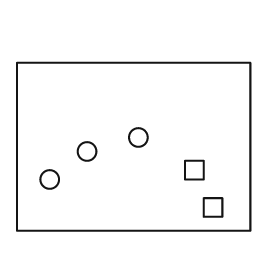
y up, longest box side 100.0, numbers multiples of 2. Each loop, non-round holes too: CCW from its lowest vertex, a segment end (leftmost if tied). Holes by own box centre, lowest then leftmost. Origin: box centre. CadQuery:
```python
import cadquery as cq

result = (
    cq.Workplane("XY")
    .moveTo(-50.0, -36.0)
    .lineTo(50.0, -36.0)
    .lineTo(50.0, 36.0)
    .lineTo(-50.0, 36.0)
    .close()
    .moveTo(30.0, -30.0)
    .lineTo(38.0, -30.0)
    .lineTo(38.0, -22.0)
    .lineTo(30.0, -22.0)
    .close()
    .moveTo(-36.0, -14.0)
    .circle(4.0)
    .moveTo(22.0, -14.0)
    .lineTo(30.0, -14.0)
    .lineTo(30.0, -6.0)
    .lineTo(22.0, -6.0)
    .close()
    .moveTo(-20.0, -2.0)
    .circle(4.0)
    .moveTo(2.0, 4.0)
    .circle(4.0)
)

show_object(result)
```